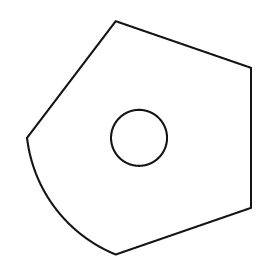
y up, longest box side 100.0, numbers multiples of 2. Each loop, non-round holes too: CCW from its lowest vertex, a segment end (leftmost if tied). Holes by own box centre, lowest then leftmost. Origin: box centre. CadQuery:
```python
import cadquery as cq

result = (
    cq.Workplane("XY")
    .moveTo(-10.0, -50.0)
    .lineTo(48.0, -30.0)
    .lineTo(48.0, 30.0)
    .lineTo(-10.0, 50.0)
    .lineTo(-48.0, 0.0)
    .threePointArc((-36.0, -30.0), (-10.0, -50.0))
    .close()
    .moveTo(0.0, 0.0)
    .circle(12.0)
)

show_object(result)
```